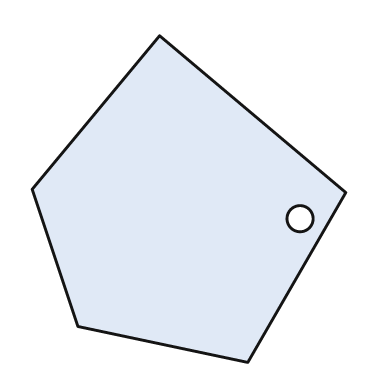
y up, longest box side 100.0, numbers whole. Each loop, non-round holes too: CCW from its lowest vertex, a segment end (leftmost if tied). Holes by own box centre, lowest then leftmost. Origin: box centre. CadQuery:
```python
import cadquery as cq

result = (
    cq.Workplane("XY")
    .moveTo(18.0, -50.0)
    .lineTo(48.0, 2.0)
    .lineTo(-9.0, 50.0)
    .lineTo(-48.0, 3.0)
    .lineTo(-34.0, -39.0)
    .close()
    .moveTo(34.0, -6.0)
    .circle(4.0)
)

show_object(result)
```